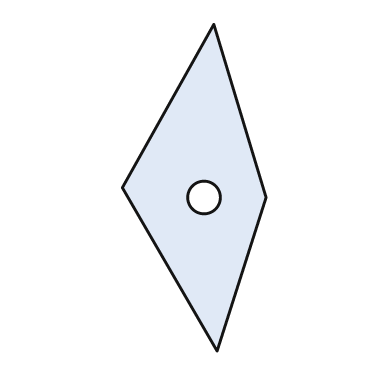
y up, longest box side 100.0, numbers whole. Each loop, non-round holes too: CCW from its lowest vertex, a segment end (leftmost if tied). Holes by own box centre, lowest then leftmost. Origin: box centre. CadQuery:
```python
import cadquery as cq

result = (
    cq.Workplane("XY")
    .moveTo(7.0, -50.0)
    .lineTo(22.0, -3.0)
    .lineTo(6.0, 50.0)
    .lineTo(-22.0, 0.0)
    .close()
    .moveTo(3.0, -3.0)
    .circle(5.0)
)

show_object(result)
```